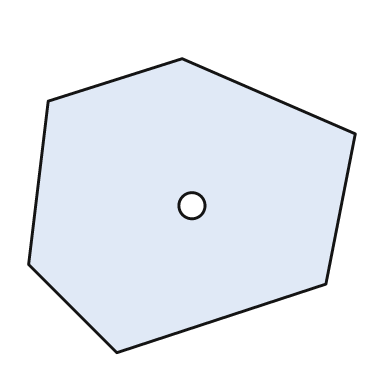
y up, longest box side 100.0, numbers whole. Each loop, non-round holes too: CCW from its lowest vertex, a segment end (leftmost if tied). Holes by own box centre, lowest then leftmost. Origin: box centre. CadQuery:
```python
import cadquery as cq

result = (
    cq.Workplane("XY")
    .moveTo(-23.0, -45.0)
    .lineTo(41.0, -24.0)
    .lineTo(50.0, 22.0)
    .lineTo(-3.0, 45.0)
    .lineTo(-44.0, 32.0)
    .lineTo(-50.0, -18.0)
    .close()
    .moveTo(0.0, 0.0)
    .circle(4.0)
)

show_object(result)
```